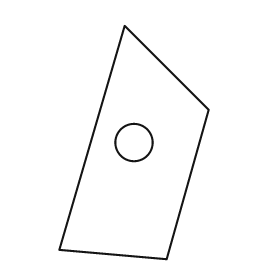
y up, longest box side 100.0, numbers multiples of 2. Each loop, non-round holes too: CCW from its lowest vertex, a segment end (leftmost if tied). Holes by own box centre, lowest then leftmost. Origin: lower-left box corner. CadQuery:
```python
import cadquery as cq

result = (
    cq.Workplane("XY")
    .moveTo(46.0, 0.0)
    .lineTo(64.0, 64.0)
    .lineTo(28.0, 100.0)
    .lineTo(0.0, 4.0)
    .close()
    .moveTo(32.0, 50.0)
    .circle(8.0)
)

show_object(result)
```